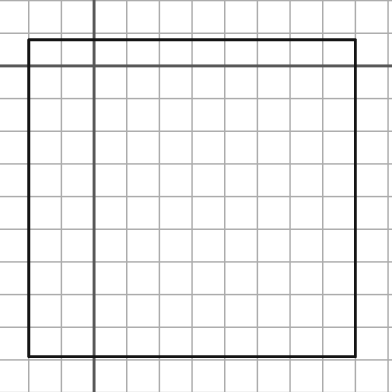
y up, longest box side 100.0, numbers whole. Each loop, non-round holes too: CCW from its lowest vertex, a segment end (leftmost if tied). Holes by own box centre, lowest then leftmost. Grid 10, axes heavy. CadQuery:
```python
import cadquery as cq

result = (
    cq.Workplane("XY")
    .moveTo(-20.0, -89.0)
    .lineTo(80.0, -89.0)
    .lineTo(80.0, 8.0)
    .lineTo(-20.0, 8.0)
    .close()
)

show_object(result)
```